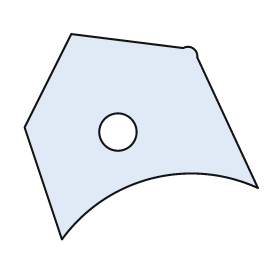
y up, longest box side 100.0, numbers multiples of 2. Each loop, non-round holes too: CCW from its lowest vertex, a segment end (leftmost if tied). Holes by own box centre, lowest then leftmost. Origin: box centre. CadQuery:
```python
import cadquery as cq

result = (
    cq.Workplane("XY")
    .moveTo(-34.0, -44.0)
    .threePointArc((4.0, -18.0), (50.0, -22.0))
    .lineTo(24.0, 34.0)
    .threePointArc((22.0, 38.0), (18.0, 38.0))
    .lineTo(-30.0, 44.0)
    .lineTo(-50.0, 4.0)
    .close()
    .moveTo(-10.0, 2.0)
    .circle(8.0)
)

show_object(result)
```